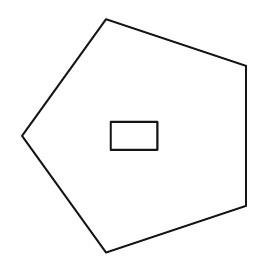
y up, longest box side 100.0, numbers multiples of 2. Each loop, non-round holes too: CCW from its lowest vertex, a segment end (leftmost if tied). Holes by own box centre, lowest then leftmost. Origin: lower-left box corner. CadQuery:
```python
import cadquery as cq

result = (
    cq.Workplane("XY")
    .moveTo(36.0, 0.0)
    .lineTo(96.0, 20.0)
    .lineTo(96.0, 80.0)
    .lineTo(36.0, 100.0)
    .lineTo(0.0, 50.0)
    .close()
    .moveTo(38.0, 44.0)
    .lineTo(58.0, 44.0)
    .lineTo(58.0, 56.0)
    .lineTo(38.0, 56.0)
    .close()
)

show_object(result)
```